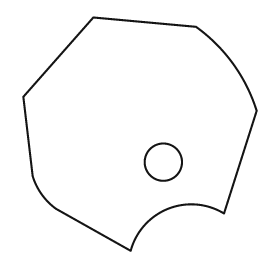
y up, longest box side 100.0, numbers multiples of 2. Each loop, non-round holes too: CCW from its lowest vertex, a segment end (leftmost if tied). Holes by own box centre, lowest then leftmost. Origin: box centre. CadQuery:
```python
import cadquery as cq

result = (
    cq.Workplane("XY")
    .moveTo(-4.0, -50.0)
    .threePointArc((12.0, -32.0), (36.0, -34.0))
    .lineTo(50.0, 10.0)
    .threePointArc((40.0, 30.0), (24.0, 46.0))
    .lineTo(-20.0, 50.0)
    .lineTo(-50.0, 16.0)
    .lineTo(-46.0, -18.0)
    .threePointArc((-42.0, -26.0), (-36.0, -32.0))
    .close()
    .moveTo(10.0, -12.0)
    .circle(8.0)
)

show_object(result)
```